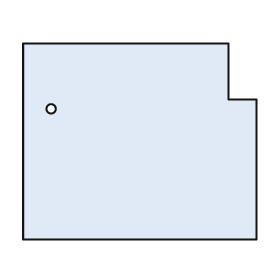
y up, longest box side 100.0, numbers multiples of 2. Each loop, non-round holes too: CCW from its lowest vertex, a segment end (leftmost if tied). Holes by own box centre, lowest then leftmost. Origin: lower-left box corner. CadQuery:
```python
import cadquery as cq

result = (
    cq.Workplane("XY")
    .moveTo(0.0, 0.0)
    .lineTo(100.0, 0.0)
    .lineTo(100.0, 60.0)
    .lineTo(88.0, 60.0)
    .lineTo(88.0, 84.0)
    .lineTo(0.0, 84.0)
    .close()
    .moveTo(12.0, 56.0)
    .circle(2.0)
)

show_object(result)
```